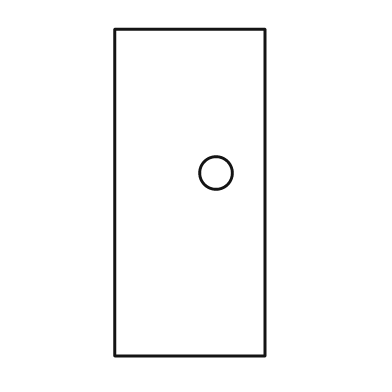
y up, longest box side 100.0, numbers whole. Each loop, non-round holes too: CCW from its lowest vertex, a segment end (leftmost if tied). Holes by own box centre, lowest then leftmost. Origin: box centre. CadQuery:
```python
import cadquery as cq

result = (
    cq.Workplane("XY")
    .moveTo(-23.0, -50.0)
    .lineTo(23.0, -50.0)
    .lineTo(23.0, 50.0)
    .lineTo(-23.0, 50.0)
    .close()
    .moveTo(8.0, 6.0)
    .circle(5.0)
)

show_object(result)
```